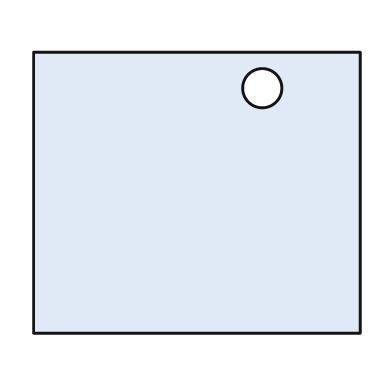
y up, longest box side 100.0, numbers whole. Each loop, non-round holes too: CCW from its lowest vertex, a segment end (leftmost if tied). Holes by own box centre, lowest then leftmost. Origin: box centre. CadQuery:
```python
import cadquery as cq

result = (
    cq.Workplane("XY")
    .moveTo(-50.0, -43.0)
    .lineTo(50.0, -43.0)
    .lineTo(50.0, 43.0)
    .lineTo(-50.0, 43.0)
    .close()
    .moveTo(20.0, 32.0)
    .circle(6.0)
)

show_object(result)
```